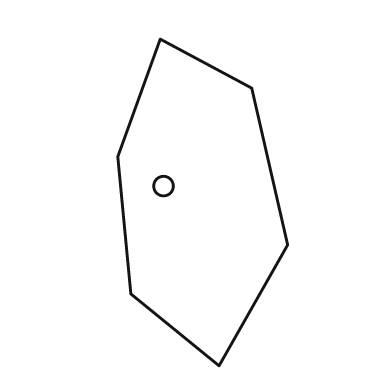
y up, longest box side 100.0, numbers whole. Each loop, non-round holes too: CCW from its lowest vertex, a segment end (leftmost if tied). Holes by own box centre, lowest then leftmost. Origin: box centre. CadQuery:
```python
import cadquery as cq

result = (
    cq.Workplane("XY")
    .moveTo(5.0, -50.0)
    .lineTo(26.0, -13.0)
    .lineTo(15.0, 35.0)
    .lineTo(-13.0, 50.0)
    .lineTo(-26.0, 14.0)
    .lineTo(-22.0, -28.0)
    .close()
    .moveTo(-12.0, 5.0)
    .circle(3.0)
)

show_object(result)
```